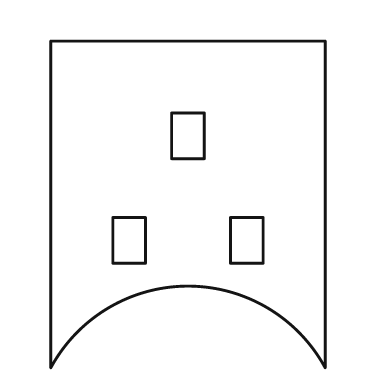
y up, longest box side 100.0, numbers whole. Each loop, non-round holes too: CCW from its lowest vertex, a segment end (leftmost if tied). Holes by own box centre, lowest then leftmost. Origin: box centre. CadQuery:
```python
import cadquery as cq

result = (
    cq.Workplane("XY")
    .moveTo(-42.0, -50.0)
    .threePointArc((0.0, -25.0), (42.0, -50.0))
    .lineTo(42.0, 50.0)
    .lineTo(-42.0, 50.0)
    .close()
    .moveTo(-23.0, -18.0)
    .lineTo(-13.0, -18.0)
    .lineTo(-13.0, -4.0)
    .lineTo(-23.0, -4.0)
    .close()
    .moveTo(13.0, -18.0)
    .lineTo(23.0, -18.0)
    .lineTo(23.0, -4.0)
    .lineTo(13.0, -4.0)
    .close()
    .moveTo(-5.0, 14.0)
    .lineTo(5.0, 14.0)
    .lineTo(5.0, 28.0)
    .lineTo(-5.0, 28.0)
    .close()
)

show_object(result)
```